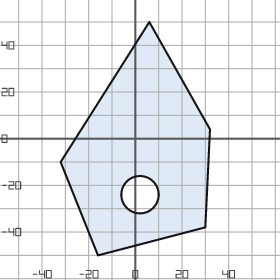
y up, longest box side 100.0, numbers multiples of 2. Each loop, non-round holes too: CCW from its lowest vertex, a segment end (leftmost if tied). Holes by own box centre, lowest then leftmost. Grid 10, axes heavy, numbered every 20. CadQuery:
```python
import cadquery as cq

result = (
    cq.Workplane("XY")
    .moveTo(-16.0, -50.0)
    .lineTo(30.0, -38.0)
    .lineTo(32.0, 4.0)
    .lineTo(6.0, 50.0)
    .lineTo(-32.0, -10.0)
    .close()
    .moveTo(2.0, -24.0)
    .circle(8.0)
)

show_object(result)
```